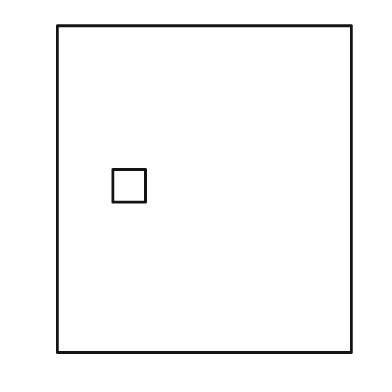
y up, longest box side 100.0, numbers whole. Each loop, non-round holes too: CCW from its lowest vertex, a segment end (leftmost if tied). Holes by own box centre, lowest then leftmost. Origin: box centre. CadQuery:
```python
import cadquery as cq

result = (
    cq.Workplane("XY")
    .moveTo(-45.0, -50.0)
    .lineTo(45.0, -50.0)
    .lineTo(45.0, 50.0)
    .lineTo(-45.0, 50.0)
    .close()
    .moveTo(-28.0, -4.0)
    .lineTo(-18.0, -4.0)
    .lineTo(-18.0, 6.0)
    .lineTo(-28.0, 6.0)
    .close()
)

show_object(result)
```